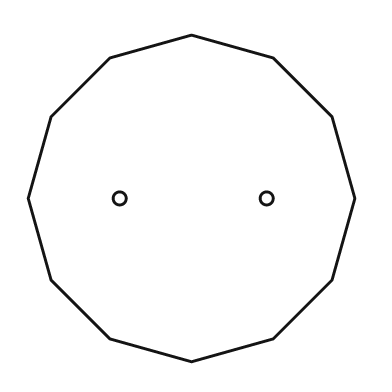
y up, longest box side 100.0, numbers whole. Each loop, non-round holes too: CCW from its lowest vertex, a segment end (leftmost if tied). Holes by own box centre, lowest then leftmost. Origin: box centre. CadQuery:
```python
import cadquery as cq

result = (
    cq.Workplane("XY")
    .moveTo(0.0, -50.0)
    .lineTo(25.0, -43.0)
    .lineTo(43.0, -25.0)
    .lineTo(50.0, 0.0)
    .lineTo(43.0, 25.0)
    .lineTo(25.0, 43.0)
    .lineTo(0.0, 50.0)
    .lineTo(-25.0, 43.0)
    .lineTo(-43.0, 25.0)
    .lineTo(-50.0, 0.0)
    .lineTo(-43.0, -25.0)
    .lineTo(-25.0, -43.0)
    .close()
    .moveTo(-22.0, 0.0)
    .circle(2.0)
    .moveTo(23.0, 0.0)
    .circle(2.0)
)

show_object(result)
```